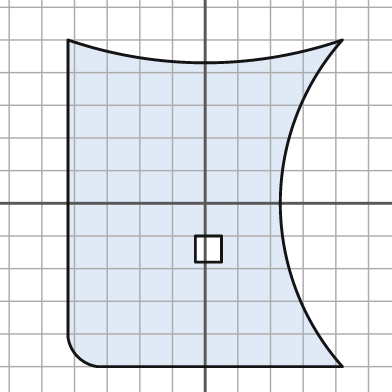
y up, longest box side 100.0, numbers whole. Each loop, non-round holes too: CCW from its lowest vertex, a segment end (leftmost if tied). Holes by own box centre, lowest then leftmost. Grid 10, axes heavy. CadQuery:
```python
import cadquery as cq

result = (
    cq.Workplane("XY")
    .moveTo(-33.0, -50.0)
    .lineTo(42.0, -50.0)
    .threePointArc((23.0, 0.0), (42.0, 50.0))
    .threePointArc((0.0, 43.0), (-42.0, 50.0))
    .lineTo(-42.0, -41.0)
    .threePointArc((-39.0, -47.0), (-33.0, -50.0))
    .close()
    .moveTo(-3.0, -18.0)
    .lineTo(5.0, -18.0)
    .lineTo(5.0, -10.0)
    .lineTo(-3.0, -10.0)
    .close()
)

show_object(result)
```